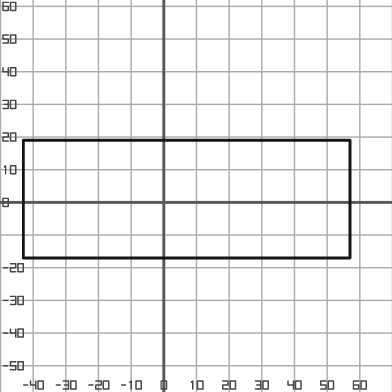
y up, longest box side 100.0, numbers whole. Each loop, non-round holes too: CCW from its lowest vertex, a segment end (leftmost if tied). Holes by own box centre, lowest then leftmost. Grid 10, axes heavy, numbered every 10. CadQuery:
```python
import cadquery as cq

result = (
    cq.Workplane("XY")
    .moveTo(-43.0, -17.0)
    .lineTo(57.0, -17.0)
    .lineTo(57.0, 19.0)
    .lineTo(-43.0, 19.0)
    .close()
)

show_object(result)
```